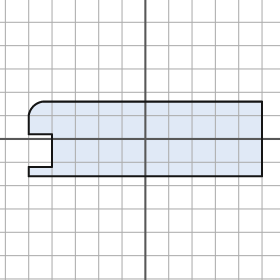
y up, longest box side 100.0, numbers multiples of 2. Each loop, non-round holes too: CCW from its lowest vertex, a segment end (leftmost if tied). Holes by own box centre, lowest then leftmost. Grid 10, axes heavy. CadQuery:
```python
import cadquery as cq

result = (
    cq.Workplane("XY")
    .moveTo(-50.0, -16.0)
    .lineTo(50.0, -16.0)
    .lineTo(50.0, 16.0)
    .lineTo(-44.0, 16.0)
    .threePointArc((-48.0, 14.0), (-50.0, 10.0))
    .lineTo(-50.0, 2.0)
    .lineTo(-40.0, 2.0)
    .lineTo(-40.0, -12.0)
    .lineTo(-50.0, -12.0)
    .close()
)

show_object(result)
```